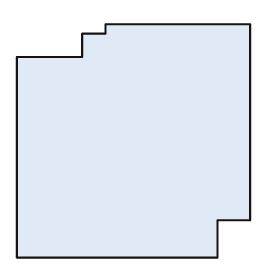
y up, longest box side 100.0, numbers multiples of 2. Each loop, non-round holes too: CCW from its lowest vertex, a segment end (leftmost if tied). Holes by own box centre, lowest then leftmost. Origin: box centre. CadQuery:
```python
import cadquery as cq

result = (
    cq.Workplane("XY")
    .moveTo(-50.0, -50.0)
    .lineTo(36.0, -50.0)
    .lineTo(36.0, -34.0)
    .lineTo(50.0, -34.0)
    .lineTo(50.0, 50.0)
    .lineTo(-12.0, 50.0)
    .lineTo(-12.0, 46.0)
    .lineTo(-22.0, 46.0)
    .lineTo(-22.0, 36.0)
    .lineTo(-50.0, 36.0)
    .close()
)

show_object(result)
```